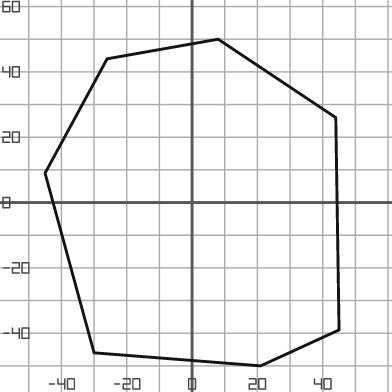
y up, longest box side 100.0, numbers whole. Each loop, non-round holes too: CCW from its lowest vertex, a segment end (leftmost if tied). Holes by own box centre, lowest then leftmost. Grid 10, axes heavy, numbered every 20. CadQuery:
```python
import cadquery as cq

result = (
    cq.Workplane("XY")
    .moveTo(21.0, -50.0)
    .lineTo(45.0, -39.0)
    .lineTo(44.0, 26.0)
    .lineTo(8.0, 50.0)
    .lineTo(-26.0, 44.0)
    .lineTo(-45.0, 9.0)
    .lineTo(-30.0, -46.0)
    .close()
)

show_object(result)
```